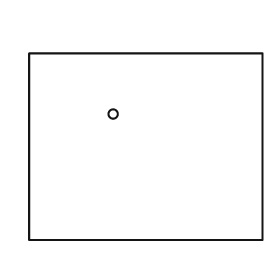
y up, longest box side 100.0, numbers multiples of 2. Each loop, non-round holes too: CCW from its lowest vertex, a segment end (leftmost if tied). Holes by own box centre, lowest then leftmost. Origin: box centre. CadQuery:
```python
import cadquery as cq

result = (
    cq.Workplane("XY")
    .moveTo(-50.0, -40.0)
    .lineTo(50.0, -40.0)
    .lineTo(50.0, 40.0)
    .lineTo(-50.0, 40.0)
    .close()
    .moveTo(-14.0, 14.0)
    .circle(2.0)
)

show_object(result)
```